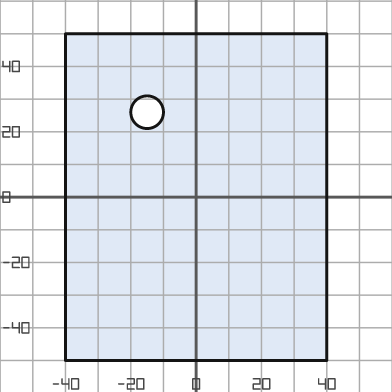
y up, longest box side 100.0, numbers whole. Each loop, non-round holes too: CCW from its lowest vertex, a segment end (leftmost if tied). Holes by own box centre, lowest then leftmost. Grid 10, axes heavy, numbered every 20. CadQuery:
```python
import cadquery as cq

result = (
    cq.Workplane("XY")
    .moveTo(-40.0, -50.0)
    .lineTo(40.0, -50.0)
    .lineTo(40.0, 50.0)
    .lineTo(-40.0, 50.0)
    .close()
    .moveTo(-15.0, 26.0)
    .circle(5.0)
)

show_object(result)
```